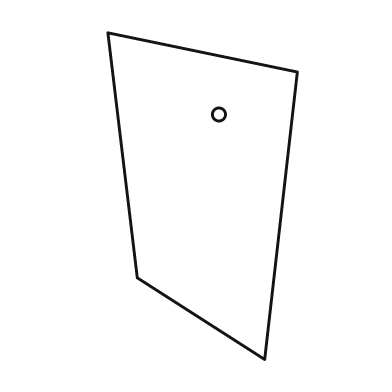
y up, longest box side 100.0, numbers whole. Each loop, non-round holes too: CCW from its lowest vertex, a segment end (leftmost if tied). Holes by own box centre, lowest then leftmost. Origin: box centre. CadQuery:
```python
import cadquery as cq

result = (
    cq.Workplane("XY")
    .moveTo(19.0, -50.0)
    .lineTo(29.0, 38.0)
    .lineTo(-29.0, 50.0)
    .lineTo(-20.0, -25.0)
    .close()
    .moveTo(5.0, 25.0)
    .circle(2.0)
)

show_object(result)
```